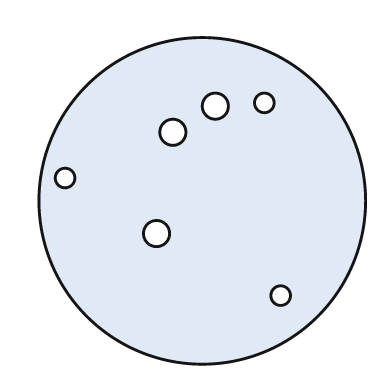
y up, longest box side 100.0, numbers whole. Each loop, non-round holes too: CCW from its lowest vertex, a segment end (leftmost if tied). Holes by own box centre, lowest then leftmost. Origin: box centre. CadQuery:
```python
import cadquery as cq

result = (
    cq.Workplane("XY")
    .moveTo(0.0, 0.0)
    .circle(50.0)
    .moveTo(24.0, -29.0)
    .circle(3.0)
    .moveTo(-14.0, -10.0)
    .circle(4.0)
    .moveTo(-42.0, 7.0)
    .circle(3.0)
    .moveTo(-9.0, 21.0)
    .circle(4.0)
    .moveTo(4.0, 29.0)
    .circle(4.0)
    .moveTo(19.0, 30.0)
    .circle(3.0)
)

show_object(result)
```